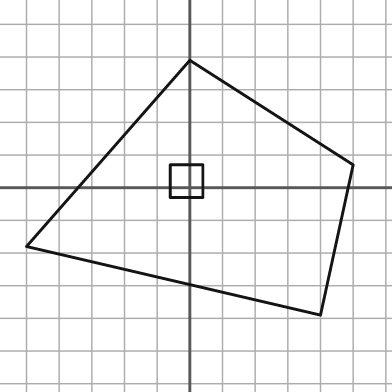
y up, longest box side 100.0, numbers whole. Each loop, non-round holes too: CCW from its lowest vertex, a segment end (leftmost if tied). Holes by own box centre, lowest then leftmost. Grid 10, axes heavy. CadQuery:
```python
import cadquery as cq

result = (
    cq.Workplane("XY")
    .moveTo(40.0, -39.0)
    .lineTo(50.0, 7.0)
    .lineTo(0.0, 39.0)
    .lineTo(-50.0, -18.0)
    .close()
    .moveTo(-6.0, -3.0)
    .lineTo(4.0, -3.0)
    .lineTo(4.0, 7.0)
    .lineTo(-6.0, 7.0)
    .close()
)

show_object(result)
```